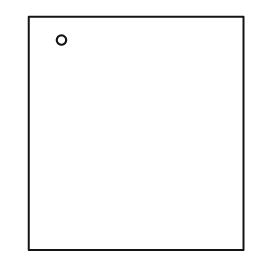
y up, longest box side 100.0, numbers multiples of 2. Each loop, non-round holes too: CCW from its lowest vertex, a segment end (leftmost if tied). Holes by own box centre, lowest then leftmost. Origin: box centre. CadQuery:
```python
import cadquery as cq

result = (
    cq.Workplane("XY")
    .moveTo(-46.0, -50.0)
    .lineTo(46.0, -50.0)
    .lineTo(46.0, 50.0)
    .lineTo(-46.0, 50.0)
    .close()
    .moveTo(-32.0, 40.0)
    .circle(2.0)
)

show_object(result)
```